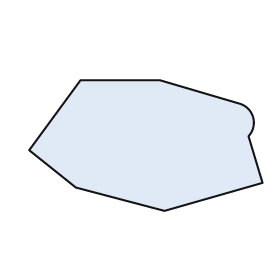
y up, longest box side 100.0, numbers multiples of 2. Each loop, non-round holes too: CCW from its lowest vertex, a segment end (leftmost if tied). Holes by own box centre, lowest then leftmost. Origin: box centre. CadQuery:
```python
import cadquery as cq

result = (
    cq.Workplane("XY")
    .moveTo(8.0, -28.0)
    .lineTo(50.0, -16.0)
    .lineTo(44.0, 4.0)
    .threePointArc((46.0, 12.0), (40.0, 18.0))
    .lineTo(6.0, 28.0)
    .lineTo(-28.0, 28.0)
    .lineTo(-50.0, -2.0)
    .lineTo(-30.0, -18.0)
    .close()
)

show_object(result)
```